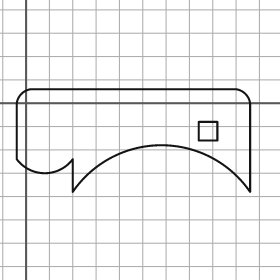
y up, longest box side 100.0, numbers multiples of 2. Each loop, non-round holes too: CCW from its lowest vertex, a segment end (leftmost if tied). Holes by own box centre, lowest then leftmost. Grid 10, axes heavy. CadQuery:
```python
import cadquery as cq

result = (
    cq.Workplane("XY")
    .moveTo(20.0, -38.0)
    .threePointArc((58.0, -18.0), (96.0, -38.0))
    .lineTo(96.0, 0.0)
    .threePointArc((94.0, 4.0), (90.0, 6.0))
    .lineTo(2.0, 6.0)
    .threePointArc((-2.0, 4.0), (-4.0, 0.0))
    .lineTo(-4.0, -24.0)
    .threePointArc((8.0, -30.0), (20.0, -24.0))
    .close()
    .moveTo(74.0, -16.0)
    .lineTo(82.0, -16.0)
    .lineTo(82.0, -8.0)
    .lineTo(74.0, -8.0)
    .close()
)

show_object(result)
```